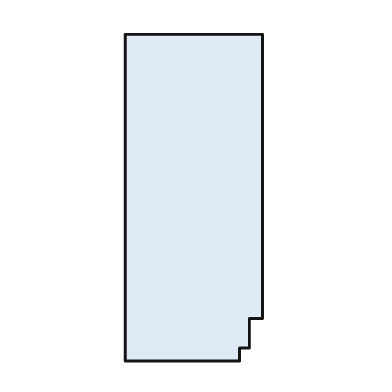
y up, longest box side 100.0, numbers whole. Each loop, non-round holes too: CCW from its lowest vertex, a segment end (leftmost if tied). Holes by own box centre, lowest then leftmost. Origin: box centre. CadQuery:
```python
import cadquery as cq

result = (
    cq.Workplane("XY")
    .moveTo(-21.0, -50.0)
    .lineTo(14.0, -50.0)
    .lineTo(14.0, -46.0)
    .lineTo(17.0, -46.0)
    .lineTo(17.0, -37.0)
    .lineTo(21.0, -37.0)
    .lineTo(21.0, 50.0)
    .lineTo(-21.0, 50.0)
    .close()
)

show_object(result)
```